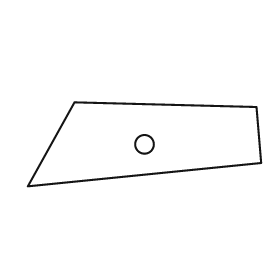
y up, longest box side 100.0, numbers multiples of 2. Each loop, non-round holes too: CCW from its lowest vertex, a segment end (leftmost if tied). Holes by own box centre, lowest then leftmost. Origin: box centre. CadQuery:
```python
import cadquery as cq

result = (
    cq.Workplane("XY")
    .moveTo(-50.0, -18.0)
    .lineTo(50.0, -8.0)
    .lineTo(48.0, 16.0)
    .lineTo(-30.0, 18.0)
    .close()
    .moveTo(0.0, 0.0)
    .circle(4.0)
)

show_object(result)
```